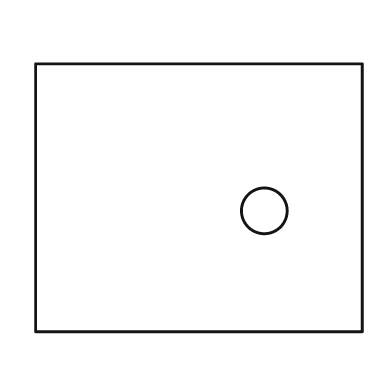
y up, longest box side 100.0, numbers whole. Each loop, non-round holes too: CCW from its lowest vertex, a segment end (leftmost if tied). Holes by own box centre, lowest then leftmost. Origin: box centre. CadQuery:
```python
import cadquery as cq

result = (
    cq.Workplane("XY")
    .moveTo(-50.0, -41.0)
    .lineTo(50.0, -41.0)
    .lineTo(50.0, 41.0)
    .lineTo(-50.0, 41.0)
    .close()
    .moveTo(20.0, -4.0)
    .circle(7.0)
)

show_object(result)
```